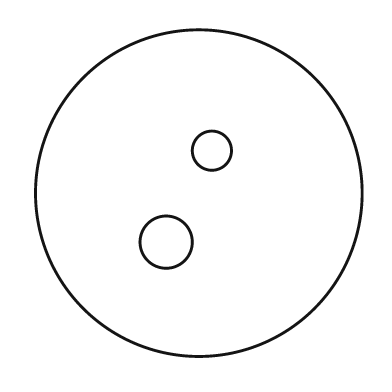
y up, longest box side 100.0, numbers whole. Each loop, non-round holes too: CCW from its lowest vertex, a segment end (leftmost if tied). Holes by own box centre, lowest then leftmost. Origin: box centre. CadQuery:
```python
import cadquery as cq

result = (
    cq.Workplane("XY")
    .moveTo(0.0, 0.0)
    .circle(50.0)
    .moveTo(-10.0, -15.0)
    .circle(8.0)
    .moveTo(4.0, 13.0)
    .circle(6.0)
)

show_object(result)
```